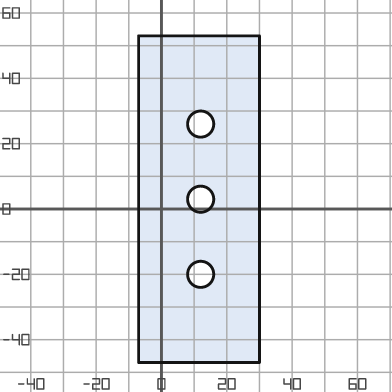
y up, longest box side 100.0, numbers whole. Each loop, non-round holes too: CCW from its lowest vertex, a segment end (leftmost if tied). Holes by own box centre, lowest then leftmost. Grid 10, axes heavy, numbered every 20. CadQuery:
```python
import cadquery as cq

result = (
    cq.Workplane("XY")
    .moveTo(-7.0, -47.0)
    .lineTo(30.0, -47.0)
    .lineTo(30.0, 53.0)
    .lineTo(-7.0, 53.0)
    .close()
    .moveTo(12.0, -20.0)
    .circle(4.0)
    .moveTo(12.0, 3.0)
    .circle(4.0)
    .moveTo(12.0, 26.0)
    .circle(4.0)
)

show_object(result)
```